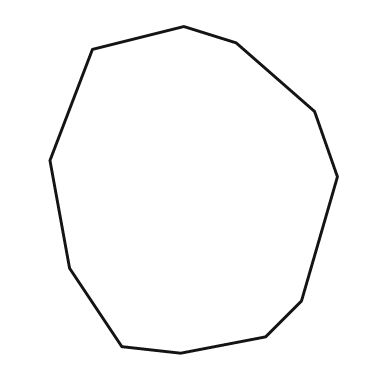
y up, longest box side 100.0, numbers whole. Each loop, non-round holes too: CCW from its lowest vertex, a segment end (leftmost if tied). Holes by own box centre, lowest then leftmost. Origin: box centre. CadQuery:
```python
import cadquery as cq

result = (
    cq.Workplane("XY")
    .moveTo(-4.0, -50.0)
    .lineTo(22.0, -45.0)
    .lineTo(33.0, -34.0)
    .lineTo(44.0, 4.0)
    .lineTo(37.0, 24.0)
    .lineTo(13.0, 45.0)
    .lineTo(-3.0, 50.0)
    .lineTo(-31.0, 43.0)
    .lineTo(-44.0, 9.0)
    .lineTo(-38.0, -24.0)
    .lineTo(-22.0, -48.0)
    .close()
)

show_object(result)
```